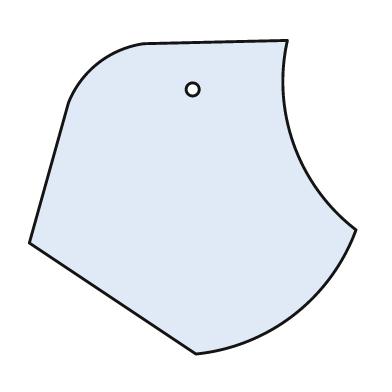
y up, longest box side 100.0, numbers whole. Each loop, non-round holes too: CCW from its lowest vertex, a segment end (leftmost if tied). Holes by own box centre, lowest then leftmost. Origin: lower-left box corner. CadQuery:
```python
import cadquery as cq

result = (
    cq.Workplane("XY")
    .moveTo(51.0, 0.0)
    .threePointArc((81.0, 12.0), (100.0, 38.0))
    .threePointArc((81.0, 64.0), (79.0, 96.0))
    .lineTo(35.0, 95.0)
    .threePointArc((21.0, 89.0), (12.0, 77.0))
    .lineTo(0.0, 34.0)
    .close()
    .moveTo(50.0, 81.0)
    .circle(2.0)
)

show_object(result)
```